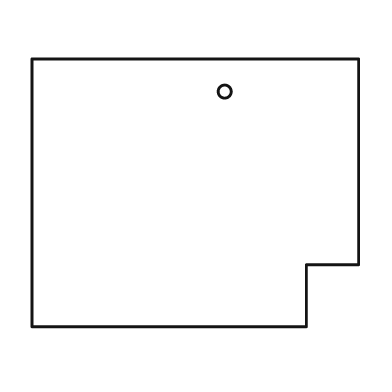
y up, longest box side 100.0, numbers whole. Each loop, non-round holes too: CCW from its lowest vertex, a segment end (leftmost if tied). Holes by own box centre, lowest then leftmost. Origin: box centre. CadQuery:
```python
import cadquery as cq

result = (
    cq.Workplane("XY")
    .moveTo(-50.0, -41.0)
    .lineTo(34.0, -41.0)
    .lineTo(34.0, -22.0)
    .lineTo(50.0, -22.0)
    .lineTo(50.0, 41.0)
    .lineTo(-50.0, 41.0)
    .close()
    .moveTo(9.0, 31.0)
    .circle(2.0)
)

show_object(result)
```